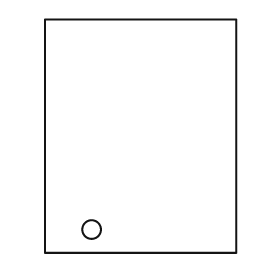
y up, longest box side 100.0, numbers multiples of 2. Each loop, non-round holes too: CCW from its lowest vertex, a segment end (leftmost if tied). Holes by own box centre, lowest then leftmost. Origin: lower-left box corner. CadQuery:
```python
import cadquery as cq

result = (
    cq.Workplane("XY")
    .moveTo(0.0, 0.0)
    .lineTo(82.0, 0.0)
    .lineTo(82.0, 100.0)
    .lineTo(0.0, 100.0)
    .close()
    .moveTo(20.0, 10.0)
    .circle(4.0)
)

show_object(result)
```